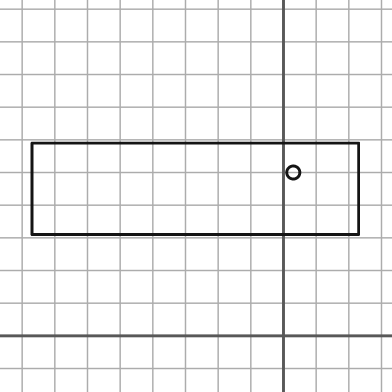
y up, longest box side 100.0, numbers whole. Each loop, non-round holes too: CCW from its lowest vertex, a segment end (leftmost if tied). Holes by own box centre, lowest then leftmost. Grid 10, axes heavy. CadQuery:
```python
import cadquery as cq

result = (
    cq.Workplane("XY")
    .moveTo(-77.0, 31.0)
    .lineTo(23.0, 31.0)
    .lineTo(23.0, 59.0)
    .lineTo(-77.0, 59.0)
    .close()
    .moveTo(3.0, 50.0)
    .circle(2.0)
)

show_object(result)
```